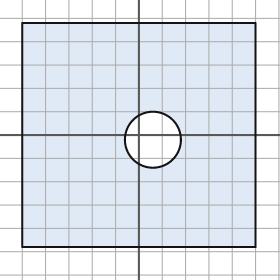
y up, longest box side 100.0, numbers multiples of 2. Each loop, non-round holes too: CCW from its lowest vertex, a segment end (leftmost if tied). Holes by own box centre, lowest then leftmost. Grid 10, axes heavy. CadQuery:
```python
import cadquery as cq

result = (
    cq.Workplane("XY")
    .moveTo(-50.0, -48.0)
    .lineTo(50.0, -48.0)
    .lineTo(50.0, 48.0)
    .lineTo(-50.0, 48.0)
    .close()
    .moveTo(6.0, -2.0)
    .circle(12.0)
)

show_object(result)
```